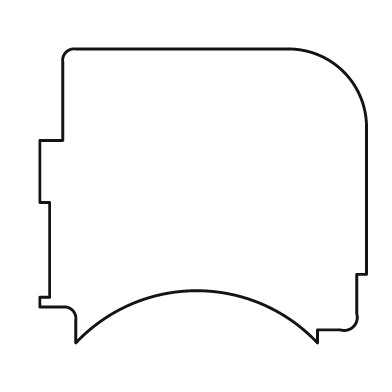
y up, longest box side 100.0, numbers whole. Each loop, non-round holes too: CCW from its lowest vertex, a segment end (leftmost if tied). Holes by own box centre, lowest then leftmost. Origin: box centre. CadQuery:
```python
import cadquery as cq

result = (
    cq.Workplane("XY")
    .moveTo(-39.0, -45.0)
    .threePointArc((-2.0, -29.0), (35.0, -45.0))
    .lineTo(35.0, -41.0)
    .lineTo(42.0, -41.0)
    .threePointArc((46.0, -40.0), (47.0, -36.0))
    .lineTo(47.0, -24.0)
    .lineTo(50.0, -24.0)
    .lineTo(50.0, 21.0)
    .threePointArc((43.0, 38.0), (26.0, 45.0))
    .lineTo(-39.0, 45.0)
    .threePointArc((-42.0, 44.0), (-43.0, 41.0))
    .lineTo(-43.0, 17.0)
    .lineTo(-50.0, 17.0)
    .lineTo(-50.0, -2.0)
    .lineTo(-47.0, -2.0)
    .lineTo(-47.0, -31.0)
    .lineTo(-50.0, -31.0)
    .lineTo(-50.0, -34.0)
    .lineTo(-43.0, -34.0)
    .threePointArc((-40.0, -35.0), (-39.0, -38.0))
    .close()
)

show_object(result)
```